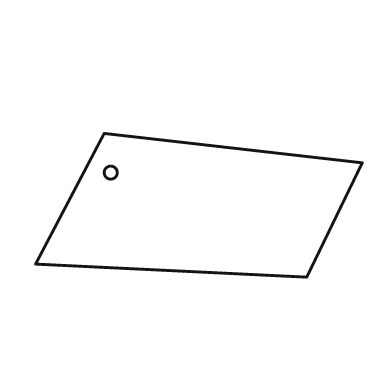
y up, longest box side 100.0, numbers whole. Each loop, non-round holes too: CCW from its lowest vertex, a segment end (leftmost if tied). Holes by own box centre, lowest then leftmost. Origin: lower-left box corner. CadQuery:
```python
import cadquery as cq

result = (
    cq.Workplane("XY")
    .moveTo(83.0, 0.0)
    .lineTo(100.0, 35.0)
    .lineTo(21.0, 44.0)
    .lineTo(0.0, 4.0)
    .close()
    .moveTo(23.0, 32.0)
    .circle(2.0)
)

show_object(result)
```